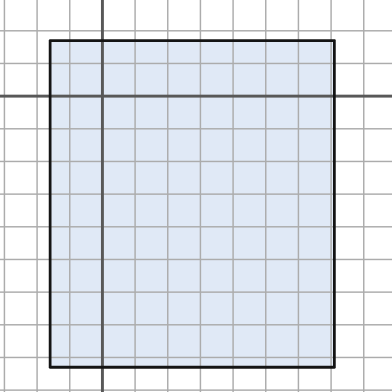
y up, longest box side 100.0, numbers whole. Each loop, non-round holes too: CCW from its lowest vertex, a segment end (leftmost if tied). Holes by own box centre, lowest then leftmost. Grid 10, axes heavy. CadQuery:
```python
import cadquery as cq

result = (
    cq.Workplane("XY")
    .moveTo(-16.0, -83.0)
    .lineTo(71.0, -83.0)
    .lineTo(71.0, 17.0)
    .lineTo(-16.0, 17.0)
    .close()
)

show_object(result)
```